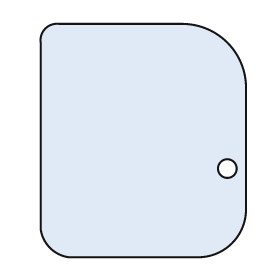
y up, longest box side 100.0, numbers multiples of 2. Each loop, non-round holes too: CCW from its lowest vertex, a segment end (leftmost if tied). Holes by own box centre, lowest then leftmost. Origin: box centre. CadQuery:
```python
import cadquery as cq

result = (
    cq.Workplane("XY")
    .moveTo(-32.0, -50.0)
    .lineTo(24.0, -50.0)
    .threePointArc((38.0, -44.0), (44.0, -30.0))
    .lineTo(44.0, 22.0)
    .threePointArc((36.0, 42.0), (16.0, 50.0))
    .lineTo(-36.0, 50.0)
    .threePointArc((-42.0, 48.0), (-44.0, 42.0))
    .lineTo(-44.0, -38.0)
    .threePointArc((-40.0, -46.0), (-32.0, -50.0))
    .close()
    .moveTo(36.0, -12.0)
    .circle(4.0)
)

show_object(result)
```